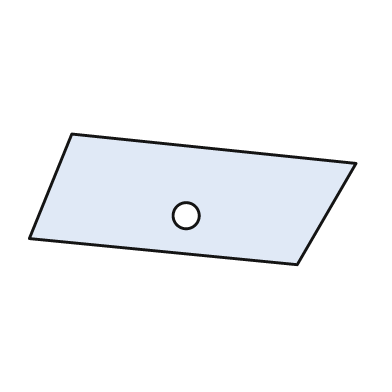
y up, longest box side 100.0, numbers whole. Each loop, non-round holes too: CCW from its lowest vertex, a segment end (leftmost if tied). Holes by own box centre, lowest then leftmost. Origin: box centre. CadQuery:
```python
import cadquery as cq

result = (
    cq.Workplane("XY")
    .moveTo(32.0, -20.0)
    .lineTo(50.0, 11.0)
    .lineTo(-37.0, 20.0)
    .lineTo(-50.0, -12.0)
    .close()
    .moveTo(-2.0, -5.0)
    .circle(4.0)
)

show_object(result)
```